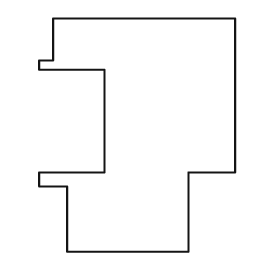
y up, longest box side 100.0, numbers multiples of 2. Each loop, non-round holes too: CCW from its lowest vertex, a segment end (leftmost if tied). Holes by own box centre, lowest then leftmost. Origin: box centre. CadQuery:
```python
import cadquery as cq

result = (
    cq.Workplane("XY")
    .moveTo(-30.0, -50.0)
    .lineTo(22.0, -50.0)
    .lineTo(22.0, -16.0)
    .lineTo(42.0, -16.0)
    .lineTo(42.0, 50.0)
    .lineTo(-36.0, 50.0)
    .lineTo(-36.0, 32.0)
    .lineTo(-42.0, 32.0)
    .lineTo(-42.0, 28.0)
    .lineTo(-14.0, 28.0)
    .lineTo(-14.0, -16.0)
    .lineTo(-42.0, -16.0)
    .lineTo(-42.0, -22.0)
    .lineTo(-30.0, -22.0)
    .close()
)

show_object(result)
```